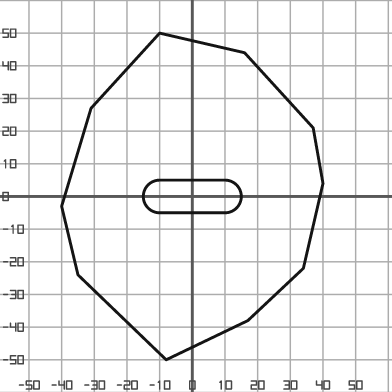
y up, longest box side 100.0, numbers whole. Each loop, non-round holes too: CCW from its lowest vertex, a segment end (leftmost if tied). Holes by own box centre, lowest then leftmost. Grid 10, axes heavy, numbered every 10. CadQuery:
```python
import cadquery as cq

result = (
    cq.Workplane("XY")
    .moveTo(-8.0, -50.0)
    .lineTo(17.0, -38.0)
    .lineTo(34.0, -22.0)
    .lineTo(40.0, 4.0)
    .lineTo(37.0, 21.0)
    .lineTo(16.0, 44.0)
    .lineTo(-10.0, 50.0)
    .lineTo(-31.0, 27.0)
    .lineTo(-40.0, -3.0)
    .lineTo(-35.0, -24.0)
    .close()
    .moveTo(-10.0, -5.0)
    .lineTo(10.0, -5.0)
    .threePointArc((15.0, 0.0), (10.0, 5.0))
    .lineTo(-10.0, 5.0)
    .threePointArc((-15.0, 0.0), (-10.0, -5.0))
    .close()
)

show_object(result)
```